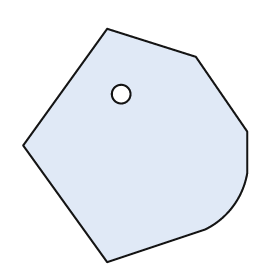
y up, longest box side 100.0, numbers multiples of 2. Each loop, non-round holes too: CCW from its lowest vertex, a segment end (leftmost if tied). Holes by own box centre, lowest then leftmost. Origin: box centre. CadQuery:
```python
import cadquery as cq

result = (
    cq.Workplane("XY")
    .moveTo(-12.0, -50.0)
    .lineTo(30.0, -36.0)
    .threePointArc((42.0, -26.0), (48.0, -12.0))
    .lineTo(48.0, 6.0)
    .lineTo(26.0, 38.0)
    .lineTo(-12.0, 50.0)
    .lineTo(-48.0, 0.0)
    .close()
    .moveTo(-6.0, 22.0)
    .circle(4.0)
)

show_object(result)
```